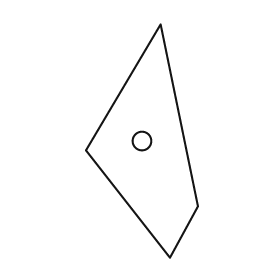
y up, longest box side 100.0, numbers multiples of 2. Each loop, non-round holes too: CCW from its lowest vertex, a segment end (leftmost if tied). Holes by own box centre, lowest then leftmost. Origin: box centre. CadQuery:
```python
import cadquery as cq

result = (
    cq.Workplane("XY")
    .moveTo(12.0, -50.0)
    .lineTo(24.0, -28.0)
    .lineTo(8.0, 50.0)
    .lineTo(-24.0, -4.0)
    .close()
    .moveTo(0.0, 0.0)
    .circle(4.0)
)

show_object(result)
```